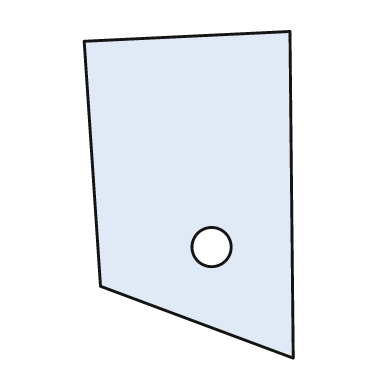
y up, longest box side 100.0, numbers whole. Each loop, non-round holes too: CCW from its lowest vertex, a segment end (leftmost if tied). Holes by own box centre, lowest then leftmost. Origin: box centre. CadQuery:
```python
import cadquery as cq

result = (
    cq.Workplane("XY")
    .moveTo(32.0, -50.0)
    .lineTo(31.0, 50.0)
    .lineTo(-32.0, 47.0)
    .lineTo(-27.0, -28.0)
    .close()
    .moveTo(7.0, -16.0)
    .circle(6.0)
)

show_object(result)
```